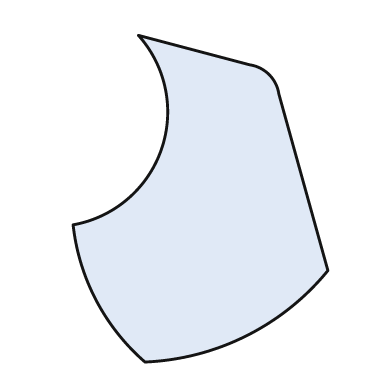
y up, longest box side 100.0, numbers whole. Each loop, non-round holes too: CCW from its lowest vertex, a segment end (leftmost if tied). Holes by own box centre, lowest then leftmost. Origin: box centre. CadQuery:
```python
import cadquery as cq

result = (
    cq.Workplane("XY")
    .moveTo(-17.0, -50.0)
    .threePointArc((14.0, -42.0), (39.0, -22.0))
    .lineTo(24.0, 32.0)
    .threePointArc((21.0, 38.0), (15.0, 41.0))
    .lineTo(-19.0, 50.0)
    .threePointArc((-12.0, 15.0), (-39.0, -8.0))
    .threePointArc((-32.0, -31.0), (-17.0, -50.0))
    .close()
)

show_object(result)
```